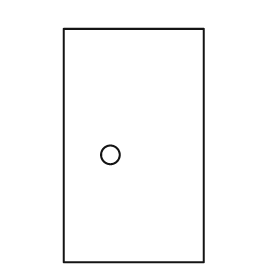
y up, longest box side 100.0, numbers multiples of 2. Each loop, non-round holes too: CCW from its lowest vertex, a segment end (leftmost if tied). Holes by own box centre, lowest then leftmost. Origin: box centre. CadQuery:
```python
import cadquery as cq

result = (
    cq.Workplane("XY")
    .moveTo(-30.0, -50.0)
    .lineTo(30.0, -50.0)
    .lineTo(30.0, 50.0)
    .lineTo(-30.0, 50.0)
    .close()
    .moveTo(-10.0, -4.0)
    .circle(4.0)
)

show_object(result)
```